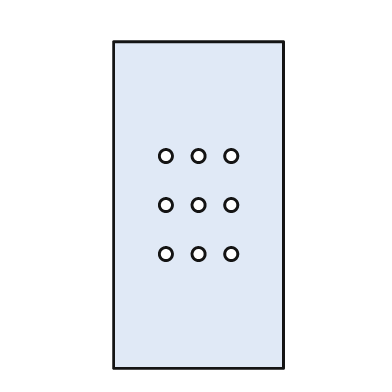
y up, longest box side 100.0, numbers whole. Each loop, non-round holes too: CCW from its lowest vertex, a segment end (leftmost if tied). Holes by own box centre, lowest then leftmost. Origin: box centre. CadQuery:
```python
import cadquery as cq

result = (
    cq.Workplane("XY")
    .moveTo(-26.0, -50.0)
    .lineTo(26.0, -50.0)
    .lineTo(26.0, 50.0)
    .lineTo(-26.0, 50.0)
    .close()
    .moveTo(-10.0, -15.0)
    .circle(2.0)
    .moveTo(0.0, -15.0)
    .circle(2.0)
    .moveTo(10.0, -15.0)
    .circle(2.0)
    .moveTo(-10.0, 0.0)
    .circle(2.0)
    .moveTo(0.0, 0.0)
    .circle(2.0)
    .moveTo(10.0, 0.0)
    .circle(2.0)
    .moveTo(-10.0, 15.0)
    .circle(2.0)
    .moveTo(0.0, 15.0)
    .circle(2.0)
    .moveTo(10.0, 15.0)
    .circle(2.0)
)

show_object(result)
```